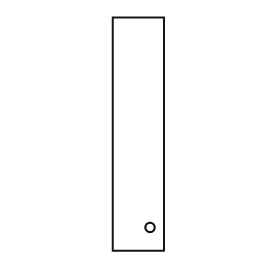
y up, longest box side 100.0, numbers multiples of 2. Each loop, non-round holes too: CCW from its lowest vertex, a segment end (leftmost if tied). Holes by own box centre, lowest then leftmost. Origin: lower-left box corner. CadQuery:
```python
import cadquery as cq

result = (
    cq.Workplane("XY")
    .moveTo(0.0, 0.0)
    .lineTo(22.0, 0.0)
    .lineTo(22.0, 100.0)
    .lineTo(0.0, 100.0)
    .close()
    .moveTo(16.0, 10.0)
    .circle(2.0)
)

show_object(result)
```